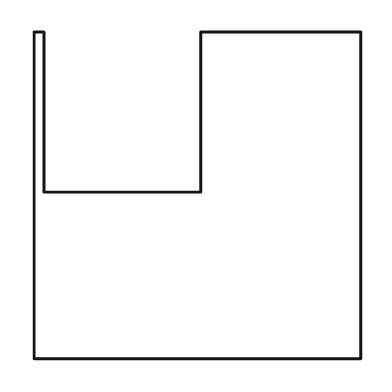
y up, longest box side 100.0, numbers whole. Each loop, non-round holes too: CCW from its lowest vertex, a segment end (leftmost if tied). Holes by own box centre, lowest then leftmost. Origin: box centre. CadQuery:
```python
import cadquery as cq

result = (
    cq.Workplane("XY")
    .moveTo(-50.0, -50.0)
    .lineTo(50.0, -50.0)
    .lineTo(50.0, 50.0)
    .lineTo(1.0, 50.0)
    .lineTo(1.0, 1.0)
    .lineTo(-47.0, 1.0)
    .lineTo(-47.0, 50.0)
    .lineTo(-50.0, 50.0)
    .close()
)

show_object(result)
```